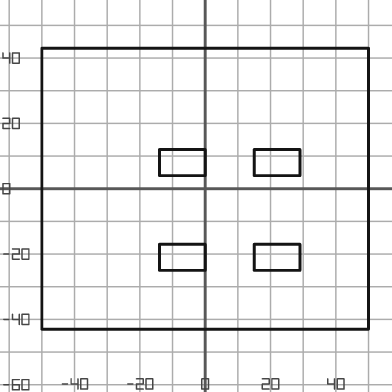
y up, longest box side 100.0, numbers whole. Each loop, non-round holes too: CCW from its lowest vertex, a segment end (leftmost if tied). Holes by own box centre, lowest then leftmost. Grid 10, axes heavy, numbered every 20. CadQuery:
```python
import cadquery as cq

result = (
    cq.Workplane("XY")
    .moveTo(-50.0, -43.0)
    .lineTo(50.0, -43.0)
    .lineTo(50.0, 43.0)
    .lineTo(-50.0, 43.0)
    .close()
    .moveTo(-14.0, -25.0)
    .lineTo(0.0, -25.0)
    .lineTo(0.0, -17.0)
    .lineTo(-14.0, -17.0)
    .close()
    .moveTo(15.0, -25.0)
    .lineTo(29.0, -25.0)
    .lineTo(29.0, -17.0)
    .lineTo(15.0, -17.0)
    .close()
    .moveTo(-14.0, 4.0)
    .lineTo(0.0, 4.0)
    .lineTo(0.0, 12.0)
    .lineTo(-14.0, 12.0)
    .close()
    .moveTo(15.0, 4.0)
    .lineTo(29.0, 4.0)
    .lineTo(29.0, 12.0)
    .lineTo(15.0, 12.0)
    .close()
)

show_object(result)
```